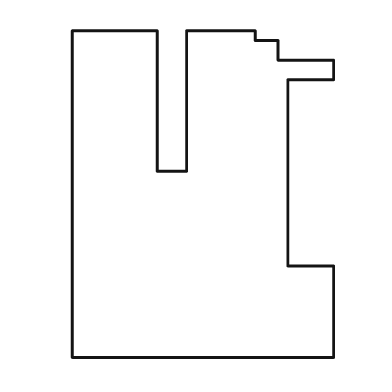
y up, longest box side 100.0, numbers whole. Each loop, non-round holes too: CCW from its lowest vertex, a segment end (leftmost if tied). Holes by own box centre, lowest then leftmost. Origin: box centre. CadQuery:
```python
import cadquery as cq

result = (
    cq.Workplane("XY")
    .moveTo(-40.0, -50.0)
    .lineTo(40.0, -50.0)
    .lineTo(40.0, -22.0)
    .lineTo(26.0, -22.0)
    .lineTo(26.0, 35.0)
    .lineTo(40.0, 35.0)
    .lineTo(40.0, 41.0)
    .lineTo(23.0, 41.0)
    .lineTo(23.0, 47.0)
    .lineTo(16.0, 47.0)
    .lineTo(16.0, 50.0)
    .lineTo(-5.0, 50.0)
    .lineTo(-5.0, 7.0)
    .lineTo(-14.0, 7.0)
    .lineTo(-14.0, 50.0)
    .lineTo(-40.0, 50.0)
    .close()
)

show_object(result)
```